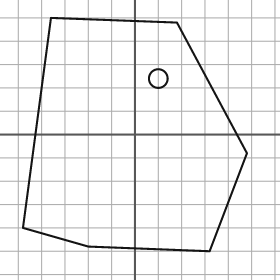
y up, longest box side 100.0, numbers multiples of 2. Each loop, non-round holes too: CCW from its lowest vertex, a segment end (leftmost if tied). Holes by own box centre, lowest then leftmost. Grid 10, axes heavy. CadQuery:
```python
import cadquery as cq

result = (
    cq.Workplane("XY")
    .moveTo(32.0, -50.0)
    .lineTo(48.0, -8.0)
    .lineTo(18.0, 48.0)
    .lineTo(-36.0, 50.0)
    .lineTo(-48.0, -40.0)
    .lineTo(-20.0, -48.0)
    .close()
    .moveTo(10.0, 24.0)
    .circle(4.0)
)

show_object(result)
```